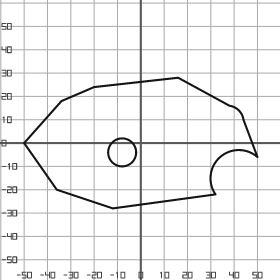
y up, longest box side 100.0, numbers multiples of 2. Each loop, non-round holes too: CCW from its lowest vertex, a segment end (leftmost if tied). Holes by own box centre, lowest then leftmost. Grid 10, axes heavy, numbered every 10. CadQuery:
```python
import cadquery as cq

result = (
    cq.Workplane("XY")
    .moveTo(-12.0, -28.0)
    .lineTo(32.0, -22.0)
    .threePointArc((34.0, -6.0), (50.0, -6.0))
    .lineTo(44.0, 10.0)
    .threePointArc((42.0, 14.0), (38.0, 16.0))
    .lineTo(16.0, 28.0)
    .lineTo(-20.0, 24.0)
    .lineTo(-34.0, 18.0)
    .lineTo(-50.0, 0.0)
    .lineTo(-36.0, -20.0)
    .close()
    .moveTo(-8.0, -4.0)
    .circle(6.0)
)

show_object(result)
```